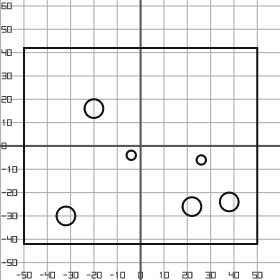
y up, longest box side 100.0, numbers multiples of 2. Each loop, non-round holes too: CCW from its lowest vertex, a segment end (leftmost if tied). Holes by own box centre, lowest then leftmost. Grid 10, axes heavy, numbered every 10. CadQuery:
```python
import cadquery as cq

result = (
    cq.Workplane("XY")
    .moveTo(-50.0, -42.0)
    .lineTo(50.0, -42.0)
    .lineTo(50.0, 42.0)
    .lineTo(-50.0, 42.0)
    .close()
    .moveTo(-32.0, -30.0)
    .circle(4.0)
    .moveTo(22.0, -26.0)
    .circle(4.0)
    .moveTo(38.0, -24.0)
    .circle(4.0)
    .moveTo(26.0, -6.0)
    .circle(2.0)
    .moveTo(-4.0, -4.0)
    .circle(2.0)
    .moveTo(-20.0, 16.0)
    .circle(4.0)
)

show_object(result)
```